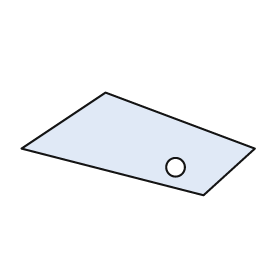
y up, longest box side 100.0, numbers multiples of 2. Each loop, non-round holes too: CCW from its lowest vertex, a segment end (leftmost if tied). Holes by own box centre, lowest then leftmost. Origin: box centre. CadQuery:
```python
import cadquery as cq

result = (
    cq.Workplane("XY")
    .moveTo(28.0, -22.0)
    .lineTo(50.0, -2.0)
    .lineTo(-14.0, 22.0)
    .lineTo(-50.0, -2.0)
    .close()
    .moveTo(16.0, -10.0)
    .circle(4.0)
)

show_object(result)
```